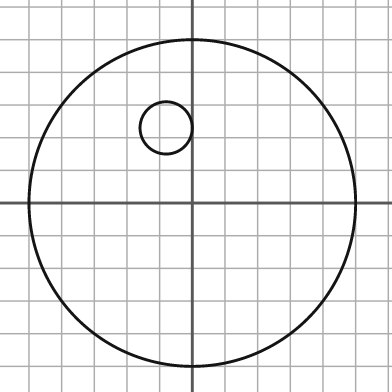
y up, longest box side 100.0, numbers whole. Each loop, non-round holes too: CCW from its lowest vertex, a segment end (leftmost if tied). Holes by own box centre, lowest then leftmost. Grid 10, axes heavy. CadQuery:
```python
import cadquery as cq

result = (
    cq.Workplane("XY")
    .moveTo(0.0, 0.0)
    .circle(50.0)
    .moveTo(-8.0, 23.0)
    .circle(8.0)
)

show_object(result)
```